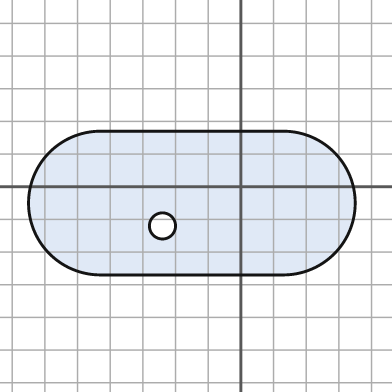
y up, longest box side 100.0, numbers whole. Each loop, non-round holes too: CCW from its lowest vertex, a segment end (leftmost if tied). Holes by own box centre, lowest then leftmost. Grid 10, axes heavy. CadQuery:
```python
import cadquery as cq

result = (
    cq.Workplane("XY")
    .moveTo(-43.0, -27.0)
    .lineTo(13.0, -27.0)
    .threePointArc((35.0, -5.0), (13.0, 17.0))
    .lineTo(-43.0, 17.0)
    .threePointArc((-65.0, -5.0), (-43.0, -27.0))
    .close()
    .moveTo(-24.0, -12.0)
    .circle(4.0)
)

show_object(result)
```